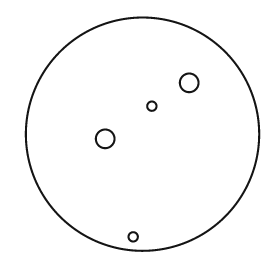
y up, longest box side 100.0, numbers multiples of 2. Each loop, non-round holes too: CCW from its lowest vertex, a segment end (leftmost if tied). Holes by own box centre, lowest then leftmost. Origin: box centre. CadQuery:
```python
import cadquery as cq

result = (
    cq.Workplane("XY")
    .moveTo(0.0, 0.0)
    .circle(50.0)
    .moveTo(-4.0, -44.0)
    .circle(2.0)
    .moveTo(-16.0, -2.0)
    .circle(4.0)
    .moveTo(4.0, 12.0)
    .circle(2.0)
    .moveTo(20.0, 22.0)
    .circle(4.0)
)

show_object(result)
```